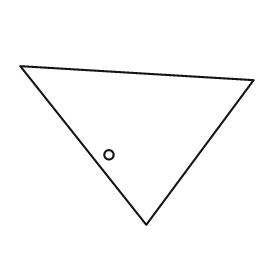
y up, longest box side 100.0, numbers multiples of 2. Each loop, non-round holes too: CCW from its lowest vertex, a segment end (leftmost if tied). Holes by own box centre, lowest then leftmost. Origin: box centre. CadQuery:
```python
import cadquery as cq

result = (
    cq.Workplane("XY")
    .moveTo(4.0, -34.0)
    .lineTo(50.0, 28.0)
    .lineTo(-50.0, 34.0)
    .close()
    .moveTo(-12.0, -4.0)
    .circle(2.0)
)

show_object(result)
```